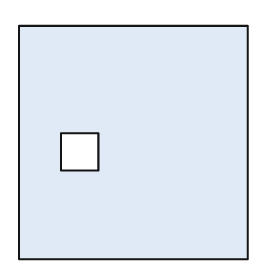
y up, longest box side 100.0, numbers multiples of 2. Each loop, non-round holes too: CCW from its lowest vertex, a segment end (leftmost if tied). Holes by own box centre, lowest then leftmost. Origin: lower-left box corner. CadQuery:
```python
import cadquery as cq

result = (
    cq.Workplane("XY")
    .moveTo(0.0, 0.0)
    .lineTo(98.0, 0.0)
    .lineTo(98.0, 100.0)
    .lineTo(0.0, 100.0)
    .close()
    .moveTo(18.0, 38.0)
    .lineTo(34.0, 38.0)
    .lineTo(34.0, 54.0)
    .lineTo(18.0, 54.0)
    .close()
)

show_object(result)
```